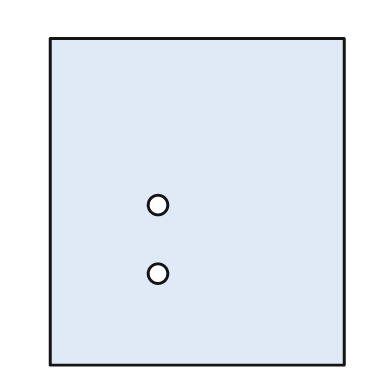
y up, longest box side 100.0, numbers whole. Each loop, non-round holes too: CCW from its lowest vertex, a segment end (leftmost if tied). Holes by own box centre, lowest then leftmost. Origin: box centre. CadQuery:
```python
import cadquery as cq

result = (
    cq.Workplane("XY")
    .moveTo(-45.0, -50.0)
    .lineTo(45.0, -50.0)
    .lineTo(45.0, 50.0)
    .lineTo(-45.0, 50.0)
    .close()
    .moveTo(-12.0, -22.0)
    .circle(3.0)
    .moveTo(-12.0, -1.0)
    .circle(3.0)
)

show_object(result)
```